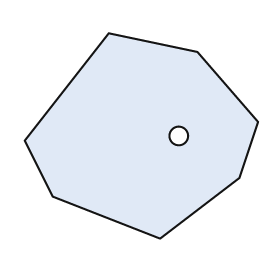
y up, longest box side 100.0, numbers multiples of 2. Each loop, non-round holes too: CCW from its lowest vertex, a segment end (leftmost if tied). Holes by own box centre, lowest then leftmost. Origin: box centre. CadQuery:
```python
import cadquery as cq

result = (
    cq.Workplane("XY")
    .moveTo(8.0, -44.0)
    .lineTo(42.0, -18.0)
    .lineTo(50.0, 6.0)
    .lineTo(24.0, 36.0)
    .lineTo(-14.0, 44.0)
    .lineTo(-50.0, -2.0)
    .lineTo(-38.0, -26.0)
    .close()
    .moveTo(16.0, 0.0)
    .circle(4.0)
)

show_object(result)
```